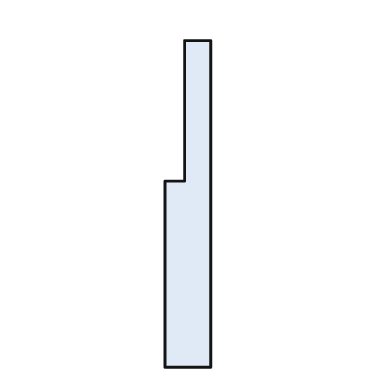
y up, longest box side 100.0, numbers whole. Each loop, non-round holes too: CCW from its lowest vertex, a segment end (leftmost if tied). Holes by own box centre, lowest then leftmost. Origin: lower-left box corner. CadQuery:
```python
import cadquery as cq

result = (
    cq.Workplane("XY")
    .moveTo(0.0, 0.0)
    .lineTo(14.0, 0.0)
    .lineTo(14.0, 100.0)
    .lineTo(6.0, 100.0)
    .lineTo(6.0, 57.0)
    .lineTo(0.0, 57.0)
    .close()
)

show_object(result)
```